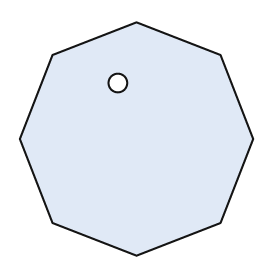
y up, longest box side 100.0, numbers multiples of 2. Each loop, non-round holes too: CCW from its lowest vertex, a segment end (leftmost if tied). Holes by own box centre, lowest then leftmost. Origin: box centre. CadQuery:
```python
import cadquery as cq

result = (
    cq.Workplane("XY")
    .moveTo(0.0, -50.0)
    .lineTo(36.0, -36.0)
    .lineTo(50.0, 0.0)
    .lineTo(36.0, 36.0)
    .lineTo(0.0, 50.0)
    .lineTo(-36.0, 36.0)
    .lineTo(-50.0, 0.0)
    .lineTo(-36.0, -36.0)
    .close()
    .moveTo(-8.0, 24.0)
    .circle(4.0)
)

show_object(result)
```